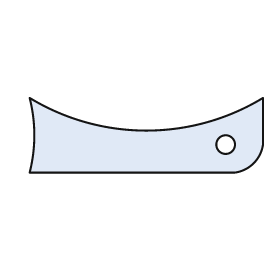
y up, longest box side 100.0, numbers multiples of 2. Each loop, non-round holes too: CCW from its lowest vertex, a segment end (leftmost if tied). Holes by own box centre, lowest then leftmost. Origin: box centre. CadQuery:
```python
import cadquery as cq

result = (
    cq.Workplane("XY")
    .moveTo(-50.0, -16.0)
    .lineTo(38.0, -16.0)
    .threePointArc((46.0, -12.0), (50.0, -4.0))
    .lineTo(50.0, 16.0)
    .threePointArc((0.0, 2.0), (-50.0, 16.0))
    .threePointArc((-48.0, 0.0), (-50.0, -16.0))
    .close()
    .moveTo(34.0, -4.0)
    .circle(4.0)
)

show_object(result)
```